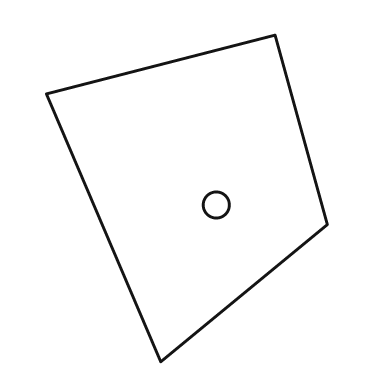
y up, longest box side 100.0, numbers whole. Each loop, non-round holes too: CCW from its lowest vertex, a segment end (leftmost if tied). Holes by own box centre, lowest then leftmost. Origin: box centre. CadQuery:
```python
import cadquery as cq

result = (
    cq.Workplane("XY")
    .moveTo(-8.0, -50.0)
    .lineTo(43.0, -8.0)
    .lineTo(27.0, 50.0)
    .lineTo(-43.0, 32.0)
    .close()
    .moveTo(9.0, -2.0)
    .circle(4.0)
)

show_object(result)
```